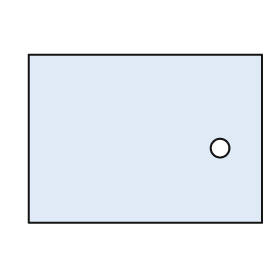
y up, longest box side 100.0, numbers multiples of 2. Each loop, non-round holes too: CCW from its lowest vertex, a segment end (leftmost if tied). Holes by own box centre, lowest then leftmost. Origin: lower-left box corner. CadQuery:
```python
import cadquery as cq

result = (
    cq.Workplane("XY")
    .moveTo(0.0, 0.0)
    .lineTo(100.0, 0.0)
    .lineTo(100.0, 72.0)
    .lineTo(0.0, 72.0)
    .close()
    .moveTo(82.0, 32.0)
    .circle(4.0)
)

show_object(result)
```